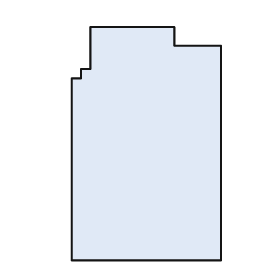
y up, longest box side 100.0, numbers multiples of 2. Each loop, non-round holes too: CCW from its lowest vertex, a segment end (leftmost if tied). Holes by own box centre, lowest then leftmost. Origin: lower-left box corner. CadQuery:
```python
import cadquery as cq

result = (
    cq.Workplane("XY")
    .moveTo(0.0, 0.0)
    .lineTo(64.0, 0.0)
    .lineTo(64.0, 92.0)
    .lineTo(44.0, 92.0)
    .lineTo(44.0, 100.0)
    .lineTo(8.0, 100.0)
    .lineTo(8.0, 82.0)
    .lineTo(4.0, 82.0)
    .lineTo(4.0, 78.0)
    .lineTo(0.0, 78.0)
    .close()
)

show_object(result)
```